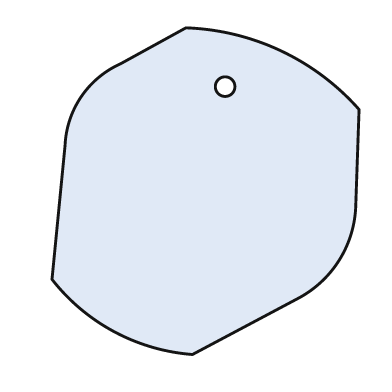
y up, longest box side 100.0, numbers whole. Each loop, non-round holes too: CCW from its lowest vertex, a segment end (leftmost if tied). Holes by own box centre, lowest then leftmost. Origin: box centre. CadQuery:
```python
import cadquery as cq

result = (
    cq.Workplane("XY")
    .moveTo(-4.0, -50.0)
    .lineTo(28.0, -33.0)
    .threePointArc((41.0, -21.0), (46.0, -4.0))
    .lineTo(47.0, 25.0)
    .threePointArc((23.0, 43.0), (-6.0, 50.0))
    .lineTo(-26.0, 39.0)
    .threePointArc((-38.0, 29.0), (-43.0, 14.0))
    .lineTo(-47.0, -27.0)
    .threePointArc((-28.0, -43.0), (-4.0, -50.0))
    .close()
    .moveTo(6.0, 32.0)
    .circle(3.0)
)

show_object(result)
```